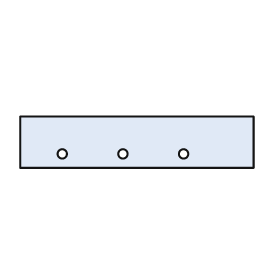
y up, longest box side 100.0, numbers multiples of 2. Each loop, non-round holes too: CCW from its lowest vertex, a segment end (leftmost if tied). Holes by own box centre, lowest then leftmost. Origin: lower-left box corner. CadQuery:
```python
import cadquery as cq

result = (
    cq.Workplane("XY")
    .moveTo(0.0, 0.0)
    .lineTo(100.0, 0.0)
    .lineTo(100.0, 22.0)
    .lineTo(0.0, 22.0)
    .close()
    .moveTo(18.0, 6.0)
    .circle(2.0)
    .moveTo(44.0, 6.0)
    .circle(2.0)
    .moveTo(70.0, 6.0)
    .circle(2.0)
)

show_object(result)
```